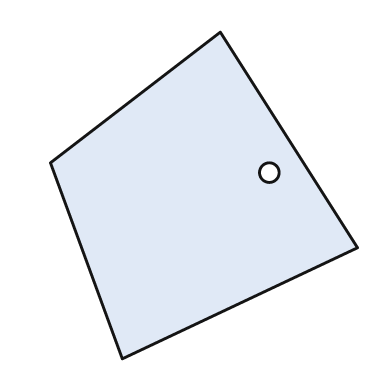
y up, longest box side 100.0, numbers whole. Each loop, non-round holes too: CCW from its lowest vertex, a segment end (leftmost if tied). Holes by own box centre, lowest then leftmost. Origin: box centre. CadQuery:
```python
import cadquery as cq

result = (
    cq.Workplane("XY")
    .moveTo(-25.0, -50.0)
    .lineTo(47.0, -16.0)
    .lineTo(5.0, 50.0)
    .lineTo(-47.0, 10.0)
    .close()
    .moveTo(20.0, 7.0)
    .circle(3.0)
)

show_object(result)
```